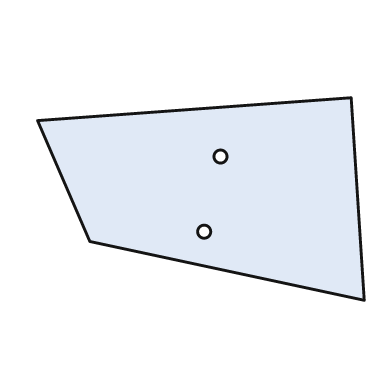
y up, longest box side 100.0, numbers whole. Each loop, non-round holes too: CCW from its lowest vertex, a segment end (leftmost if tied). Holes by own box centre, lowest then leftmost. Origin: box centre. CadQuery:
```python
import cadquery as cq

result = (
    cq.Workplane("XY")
    .moveTo(50.0, -31.0)
    .lineTo(46.0, 31.0)
    .lineTo(-50.0, 24.0)
    .lineTo(-34.0, -13.0)
    .close()
    .moveTo(1.0, -10.0)
    .circle(2.0)
    .moveTo(6.0, 13.0)
    .circle(2.0)
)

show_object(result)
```